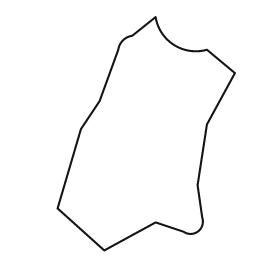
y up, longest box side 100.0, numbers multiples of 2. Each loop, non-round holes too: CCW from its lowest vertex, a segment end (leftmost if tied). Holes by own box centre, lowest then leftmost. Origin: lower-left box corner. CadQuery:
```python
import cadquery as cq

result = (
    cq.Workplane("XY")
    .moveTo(20.0, 0.0)
    .lineTo(42.0, 12.0)
    .lineTo(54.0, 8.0)
    .threePointArc((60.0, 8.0), (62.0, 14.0))
    .lineTo(60.0, 28.0)
    .lineTo(64.0, 54.0)
    .lineTo(76.0, 76.0)
    .lineTo(64.0, 86.0)
    .threePointArc((50.0, 88.0), (42.0, 100.0))
    .lineTo(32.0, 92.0)
    .threePointArc((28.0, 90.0), (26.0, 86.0))
    .lineTo(18.0, 64.0)
    .lineTo(10.0, 52.0)
    .lineTo(0.0, 18.0)
    .close()
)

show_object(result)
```